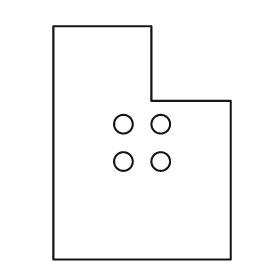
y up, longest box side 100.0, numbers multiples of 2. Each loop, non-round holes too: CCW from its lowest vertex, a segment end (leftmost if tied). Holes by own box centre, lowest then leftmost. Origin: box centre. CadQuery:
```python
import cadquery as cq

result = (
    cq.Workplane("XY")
    .moveTo(-38.0, -50.0)
    .lineTo(38.0, -50.0)
    .lineTo(38.0, 18.0)
    .lineTo(4.0, 18.0)
    .lineTo(4.0, 50.0)
    .lineTo(-38.0, 50.0)
    .close()
    .moveTo(-8.0, -8.0)
    .circle(4.0)
    .moveTo(8.0, -8.0)
    .circle(4.0)
    .moveTo(-8.0, 8.0)
    .circle(4.0)
    .moveTo(8.0, 8.0)
    .circle(4.0)
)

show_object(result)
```